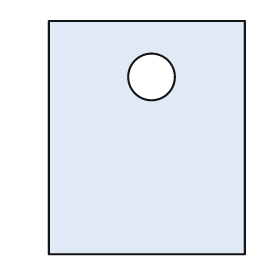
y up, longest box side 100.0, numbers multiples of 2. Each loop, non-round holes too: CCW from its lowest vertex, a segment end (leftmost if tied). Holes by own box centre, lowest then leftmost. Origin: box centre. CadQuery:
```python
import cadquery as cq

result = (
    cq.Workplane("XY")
    .moveTo(-42.0, -50.0)
    .lineTo(42.0, -50.0)
    .lineTo(42.0, 50.0)
    .lineTo(-42.0, 50.0)
    .close()
    .moveTo(2.0, 26.0)
    .circle(10.0)
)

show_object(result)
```